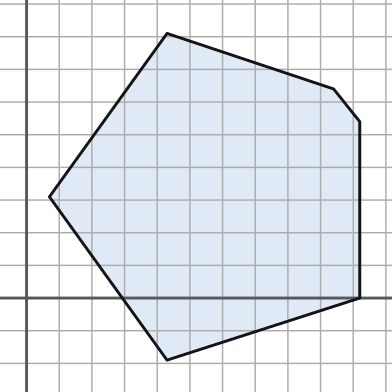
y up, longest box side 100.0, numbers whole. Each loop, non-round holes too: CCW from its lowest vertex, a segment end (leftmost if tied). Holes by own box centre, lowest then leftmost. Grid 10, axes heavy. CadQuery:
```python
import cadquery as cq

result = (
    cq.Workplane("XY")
    .moveTo(43.0, -19.0)
    .lineTo(102.0, 0.0)
    .lineTo(102.0, 54.0)
    .lineTo(94.0, 64.0)
    .lineTo(43.0, 81.0)
    .lineTo(7.0, 31.0)
    .close()
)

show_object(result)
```